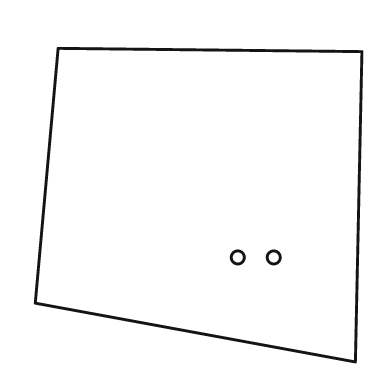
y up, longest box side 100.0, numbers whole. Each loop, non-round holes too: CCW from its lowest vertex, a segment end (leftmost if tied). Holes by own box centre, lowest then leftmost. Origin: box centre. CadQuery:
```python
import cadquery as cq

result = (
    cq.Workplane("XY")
    .moveTo(48.0, -48.0)
    .lineTo(50.0, 47.0)
    .lineTo(-43.0, 48.0)
    .lineTo(-50.0, -30.0)
    .close()
    .moveTo(12.0, -16.0)
    .circle(2.0)
    .moveTo(23.0, -16.0)
    .circle(2.0)
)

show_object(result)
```